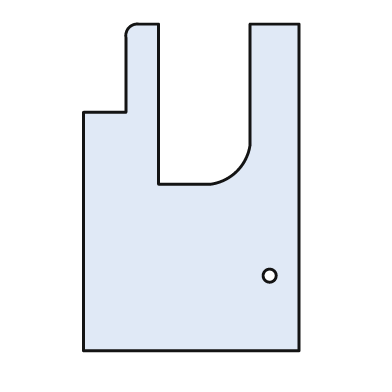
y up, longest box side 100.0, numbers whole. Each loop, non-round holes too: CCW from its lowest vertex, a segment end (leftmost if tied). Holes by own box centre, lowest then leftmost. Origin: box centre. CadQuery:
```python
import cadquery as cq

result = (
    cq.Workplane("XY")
    .moveTo(-33.0, -50.0)
    .lineTo(33.0, -50.0)
    .lineTo(33.0, 50.0)
    .lineTo(18.0, 50.0)
    .lineTo(18.0, 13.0)
    .threePointArc((14.0, 5.0), (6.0, 1.0))
    .lineTo(-10.0, 1.0)
    .lineTo(-10.0, 50.0)
    .lineTo(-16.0, 50.0)
    .threePointArc((-19.0, 49.0), (-20.0, 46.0))
    .lineTo(-20.0, 23.0)
    .lineTo(-33.0, 23.0)
    .close()
    .moveTo(24.0, -27.0)
    .circle(2.0)
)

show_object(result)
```